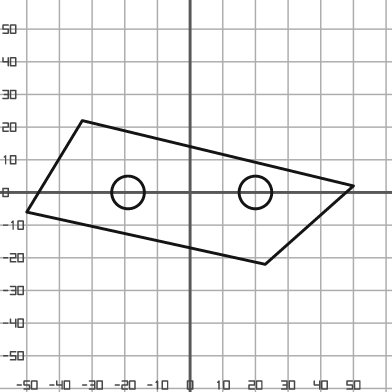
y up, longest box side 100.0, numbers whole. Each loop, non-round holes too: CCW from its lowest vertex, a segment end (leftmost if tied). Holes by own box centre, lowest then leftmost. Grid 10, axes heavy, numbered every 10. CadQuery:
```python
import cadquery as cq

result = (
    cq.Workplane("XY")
    .moveTo(23.0, -22.0)
    .lineTo(50.0, 2.0)
    .lineTo(-33.0, 22.0)
    .lineTo(-50.0, -6.0)
    .close()
    .moveTo(-19.0, 0.0)
    .circle(5.0)
    .moveTo(20.0, 0.0)
    .circle(5.0)
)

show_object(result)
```